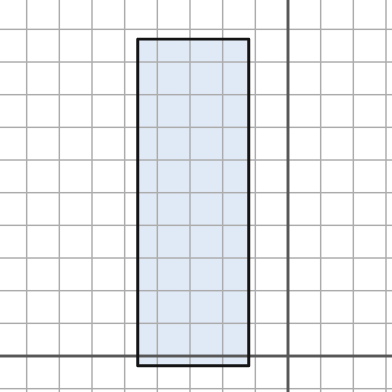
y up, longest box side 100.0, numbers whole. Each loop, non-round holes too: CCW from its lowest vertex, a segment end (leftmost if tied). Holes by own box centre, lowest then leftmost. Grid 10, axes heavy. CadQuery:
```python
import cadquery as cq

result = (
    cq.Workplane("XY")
    .moveTo(-46.0, -3.0)
    .lineTo(-12.0, -3.0)
    .lineTo(-12.0, 97.0)
    .lineTo(-46.0, 97.0)
    .close()
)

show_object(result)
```